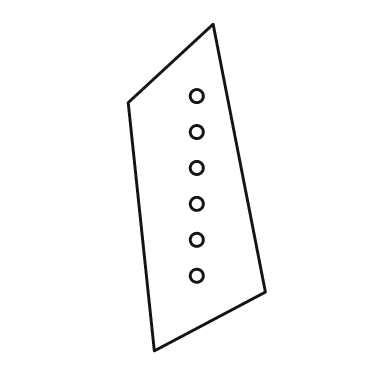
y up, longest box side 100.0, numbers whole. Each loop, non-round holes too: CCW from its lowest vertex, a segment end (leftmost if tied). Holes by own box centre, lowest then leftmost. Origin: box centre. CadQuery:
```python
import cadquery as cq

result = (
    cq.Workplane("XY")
    .moveTo(-13.0, -50.0)
    .lineTo(21.0, -32.0)
    .lineTo(5.0, 50.0)
    .lineTo(-21.0, 26.0)
    .close()
    .moveTo(0.0, -27.0)
    .circle(2.0)
    .moveTo(0.0, -16.0)
    .circle(2.0)
    .moveTo(0.0, -5.0)
    .circle(2.0)
    .moveTo(0.0, 6.0)
    .circle(2.0)
    .moveTo(0.0, 17.0)
    .circle(2.0)
    .moveTo(0.0, 28.0)
    .circle(2.0)
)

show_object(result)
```